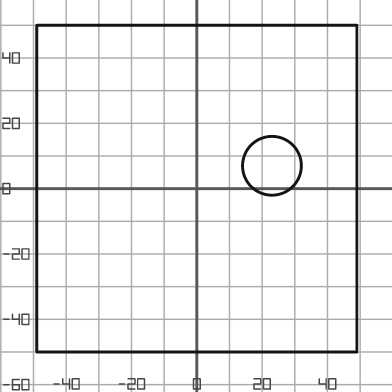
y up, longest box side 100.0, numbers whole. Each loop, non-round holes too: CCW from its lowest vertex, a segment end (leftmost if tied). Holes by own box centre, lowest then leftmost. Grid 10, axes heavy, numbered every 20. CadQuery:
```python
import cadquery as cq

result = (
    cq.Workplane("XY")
    .moveTo(-49.0, -50.0)
    .lineTo(49.0, -50.0)
    .lineTo(49.0, 50.0)
    .lineTo(-49.0, 50.0)
    .close()
    .moveTo(23.0, 7.0)
    .circle(9.0)
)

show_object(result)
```